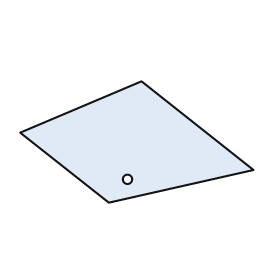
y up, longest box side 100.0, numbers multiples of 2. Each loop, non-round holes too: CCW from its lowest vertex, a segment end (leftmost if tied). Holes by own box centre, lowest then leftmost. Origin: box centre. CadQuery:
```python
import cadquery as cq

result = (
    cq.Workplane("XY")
    .moveTo(-12.0, -26.0)
    .lineTo(50.0, -12.0)
    .lineTo(2.0, 26.0)
    .lineTo(-50.0, 4.0)
    .close()
    .moveTo(-4.0, -16.0)
    .circle(2.0)
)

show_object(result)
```